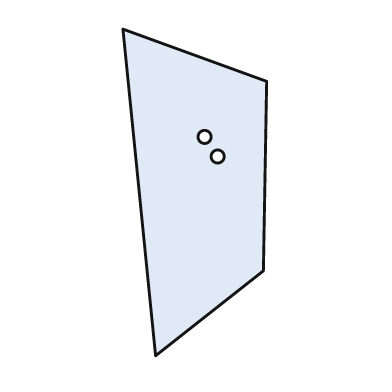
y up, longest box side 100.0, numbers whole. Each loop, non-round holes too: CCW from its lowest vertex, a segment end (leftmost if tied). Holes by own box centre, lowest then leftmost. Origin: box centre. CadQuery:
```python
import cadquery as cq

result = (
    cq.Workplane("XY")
    .moveTo(-12.0, -50.0)
    .lineTo(21.0, -24.0)
    .lineTo(22.0, 34.0)
    .lineTo(-22.0, 50.0)
    .close()
    .moveTo(7.0, 11.0)
    .circle(2.0)
    .moveTo(3.0, 17.0)
    .circle(2.0)
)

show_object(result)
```